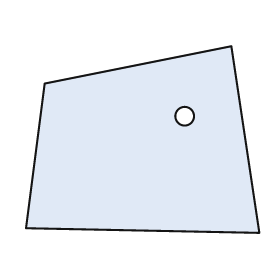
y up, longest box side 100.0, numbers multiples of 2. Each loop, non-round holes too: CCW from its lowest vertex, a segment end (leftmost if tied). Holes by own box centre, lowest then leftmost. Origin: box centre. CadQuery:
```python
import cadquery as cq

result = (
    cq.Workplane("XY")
    .moveTo(50.0, -40.0)
    .lineTo(38.0, 40.0)
    .lineTo(-42.0, 24.0)
    .lineTo(-50.0, -38.0)
    .close()
    .moveTo(18.0, 10.0)
    .circle(4.0)
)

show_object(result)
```